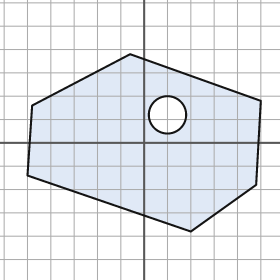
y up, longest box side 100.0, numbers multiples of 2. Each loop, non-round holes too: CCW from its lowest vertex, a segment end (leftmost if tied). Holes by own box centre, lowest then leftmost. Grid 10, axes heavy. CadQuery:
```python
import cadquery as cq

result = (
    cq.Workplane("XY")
    .moveTo(20.0, -38.0)
    .lineTo(48.0, -18.0)
    .lineTo(50.0, 18.0)
    .lineTo(-6.0, 38.0)
    .lineTo(-48.0, 16.0)
    .lineTo(-50.0, -14.0)
    .close()
    .moveTo(10.0, 12.0)
    .circle(8.0)
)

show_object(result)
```